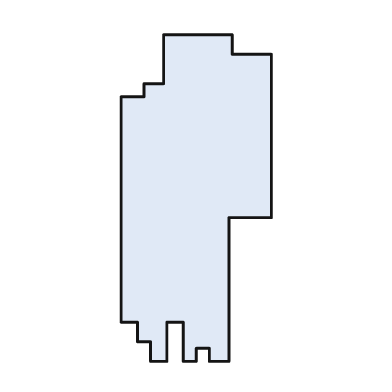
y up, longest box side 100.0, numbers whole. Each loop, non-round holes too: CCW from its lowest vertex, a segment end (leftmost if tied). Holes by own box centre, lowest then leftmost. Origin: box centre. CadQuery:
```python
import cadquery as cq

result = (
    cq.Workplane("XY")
    .moveTo(-14.0, -50.0)
    .lineTo(-9.0, -50.0)
    .lineTo(-9.0, -38.0)
    .lineTo(-4.0, -38.0)
    .lineTo(-4.0, -50.0)
    .lineTo(0.0, -50.0)
    .lineTo(0.0, -46.0)
    .lineTo(4.0, -46.0)
    .lineTo(4.0, -50.0)
    .lineTo(10.0, -50.0)
    .lineTo(10.0, -6.0)
    .lineTo(23.0, -6.0)
    .lineTo(23.0, 44.0)
    .lineTo(11.0, 44.0)
    .lineTo(11.0, 50.0)
    .lineTo(-10.0, 50.0)
    .lineTo(-10.0, 35.0)
    .lineTo(-16.0, 35.0)
    .lineTo(-16.0, 31.0)
    .lineTo(-23.0, 31.0)
    .lineTo(-23.0, -38.0)
    .lineTo(-18.0, -38.0)
    .lineTo(-18.0, -44.0)
    .lineTo(-14.0, -44.0)
    .close()
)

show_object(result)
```